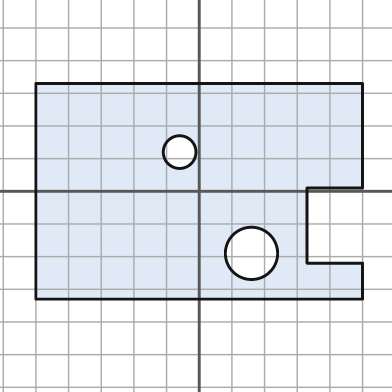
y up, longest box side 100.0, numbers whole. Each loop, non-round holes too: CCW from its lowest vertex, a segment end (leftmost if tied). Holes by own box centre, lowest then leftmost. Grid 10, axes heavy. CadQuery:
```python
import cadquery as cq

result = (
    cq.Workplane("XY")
    .moveTo(-50.0, -33.0)
    .lineTo(50.0, -33.0)
    .lineTo(50.0, -22.0)
    .lineTo(33.0, -22.0)
    .lineTo(33.0, 1.0)
    .lineTo(50.0, 1.0)
    .lineTo(50.0, 33.0)
    .lineTo(-50.0, 33.0)
    .close()
    .moveTo(16.0, -19.0)
    .circle(8.0)
    .moveTo(-6.0, 12.0)
    .circle(5.0)
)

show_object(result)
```